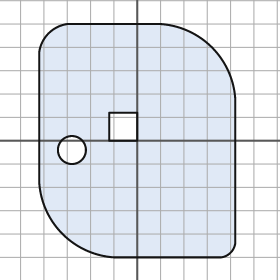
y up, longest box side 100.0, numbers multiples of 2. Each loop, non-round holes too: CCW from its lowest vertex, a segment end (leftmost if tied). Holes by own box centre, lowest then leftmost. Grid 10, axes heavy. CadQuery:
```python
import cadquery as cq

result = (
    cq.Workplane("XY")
    .moveTo(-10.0, -50.0)
    .lineTo(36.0, -50.0)
    .threePointArc((40.0, -48.0), (42.0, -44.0))
    .lineTo(42.0, 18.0)
    .threePointArc((32.0, 40.0), (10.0, 50.0))
    .lineTo(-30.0, 50.0)
    .threePointArc((-38.0, 46.0), (-42.0, 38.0))
    .lineTo(-42.0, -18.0)
    .threePointArc((-32.0, -40.0), (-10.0, -50.0))
    .close()
    .moveTo(-28.0, -4.0)
    .circle(6.0)
    .moveTo(-12.0, 0.0)
    .lineTo(0.0, 0.0)
    .lineTo(0.0, 12.0)
    .lineTo(-12.0, 12.0)
    .close()
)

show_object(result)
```